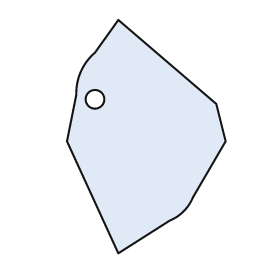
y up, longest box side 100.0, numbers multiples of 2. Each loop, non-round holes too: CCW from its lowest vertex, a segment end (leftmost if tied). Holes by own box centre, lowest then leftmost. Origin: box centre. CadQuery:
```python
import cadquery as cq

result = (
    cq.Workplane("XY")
    .moveTo(-12.0, -50.0)
    .lineTo(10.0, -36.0)
    .threePointArc((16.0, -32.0), (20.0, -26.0))
    .lineTo(34.0, -2.0)
    .lineTo(30.0, 14.0)
    .lineTo(-12.0, 50.0)
    .lineTo(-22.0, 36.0)
    .threePointArc((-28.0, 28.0), (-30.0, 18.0))
    .lineTo(-34.0, -2.0)
    .close()
    .moveTo(-22.0, 16.0)
    .circle(4.0)
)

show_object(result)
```